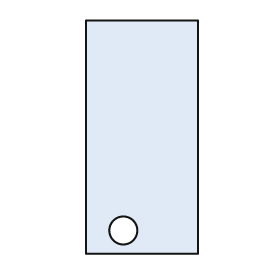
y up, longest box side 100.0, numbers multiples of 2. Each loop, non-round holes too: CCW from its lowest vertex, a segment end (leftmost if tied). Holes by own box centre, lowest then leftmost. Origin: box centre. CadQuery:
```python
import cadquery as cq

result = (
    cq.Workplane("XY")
    .moveTo(-24.0, -50.0)
    .lineTo(24.0, -50.0)
    .lineTo(24.0, 50.0)
    .lineTo(-24.0, 50.0)
    .close()
    .moveTo(-8.0, -40.0)
    .circle(6.0)
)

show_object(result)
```